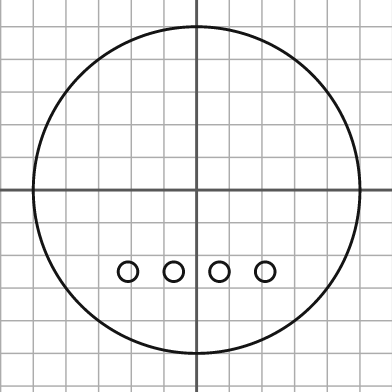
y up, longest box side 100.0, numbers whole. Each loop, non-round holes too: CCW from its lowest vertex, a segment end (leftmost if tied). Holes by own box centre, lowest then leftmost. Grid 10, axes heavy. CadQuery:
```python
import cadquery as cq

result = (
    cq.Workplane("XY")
    .moveTo(0.0, 0.0)
    .circle(50.0)
    .moveTo(-21.0, -25.0)
    .circle(3.0)
    .moveTo(-7.0, -25.0)
    .circle(3.0)
    .moveTo(7.0, -25.0)
    .circle(3.0)
    .moveTo(21.0, -25.0)
    .circle(3.0)
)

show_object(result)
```